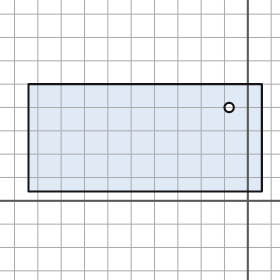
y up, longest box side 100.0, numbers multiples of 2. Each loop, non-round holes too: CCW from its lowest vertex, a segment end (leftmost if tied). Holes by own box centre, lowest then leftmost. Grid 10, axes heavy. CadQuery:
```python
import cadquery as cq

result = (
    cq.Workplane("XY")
    .moveTo(-94.0, 4.0)
    .lineTo(6.0, 4.0)
    .lineTo(6.0, 50.0)
    .lineTo(-94.0, 50.0)
    .close()
    .moveTo(-8.0, 40.0)
    .circle(2.0)
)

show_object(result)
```